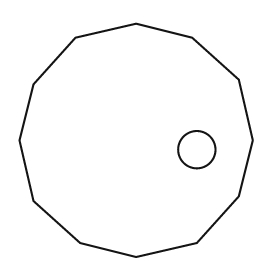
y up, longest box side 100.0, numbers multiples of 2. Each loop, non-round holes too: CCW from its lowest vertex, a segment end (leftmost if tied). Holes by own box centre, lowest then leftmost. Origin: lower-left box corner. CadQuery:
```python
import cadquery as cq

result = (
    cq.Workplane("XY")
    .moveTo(50.0, 0.0)
    .lineTo(76.0, 6.0)
    .lineTo(94.0, 26.0)
    .lineTo(100.0, 50.0)
    .lineTo(94.0, 76.0)
    .lineTo(74.0, 94.0)
    .lineTo(50.0, 100.0)
    .lineTo(24.0, 94.0)
    .lineTo(6.0, 74.0)
    .lineTo(0.0, 50.0)
    .lineTo(6.0, 24.0)
    .lineTo(26.0, 6.0)
    .close()
    .moveTo(76.0, 46.0)
    .circle(8.0)
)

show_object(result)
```